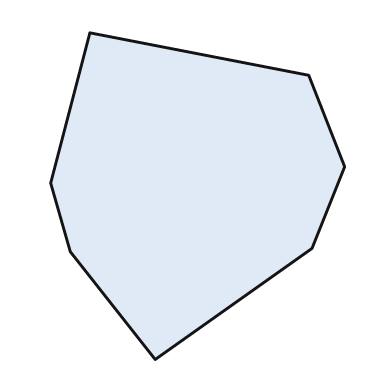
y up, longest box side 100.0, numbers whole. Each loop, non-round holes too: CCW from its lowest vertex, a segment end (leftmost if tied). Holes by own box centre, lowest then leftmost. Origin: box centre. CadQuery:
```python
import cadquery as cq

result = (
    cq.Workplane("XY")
    .moveTo(-13.0, -50.0)
    .lineTo(35.0, -16.0)
    .lineTo(45.0, 9.0)
    .lineTo(34.0, 37.0)
    .lineTo(-33.0, 50.0)
    .lineTo(-45.0, 4.0)
    .lineTo(-39.0, -17.0)
    .close()
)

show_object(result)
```